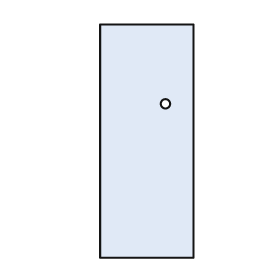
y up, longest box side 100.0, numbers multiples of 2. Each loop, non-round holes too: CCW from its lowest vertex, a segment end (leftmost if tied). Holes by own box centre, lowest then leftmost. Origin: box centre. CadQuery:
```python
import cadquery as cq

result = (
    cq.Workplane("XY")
    .moveTo(-20.0, -50.0)
    .lineTo(20.0, -50.0)
    .lineTo(20.0, 50.0)
    .lineTo(-20.0, 50.0)
    .close()
    .moveTo(8.0, 16.0)
    .circle(2.0)
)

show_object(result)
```